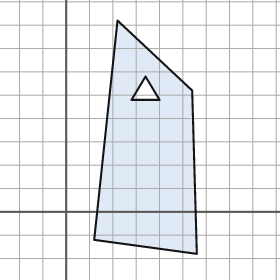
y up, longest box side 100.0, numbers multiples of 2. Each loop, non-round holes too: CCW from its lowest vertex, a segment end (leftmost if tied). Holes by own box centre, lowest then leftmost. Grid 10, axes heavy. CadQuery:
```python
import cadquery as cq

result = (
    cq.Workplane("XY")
    .moveTo(56.0, -18.0)
    .lineTo(54.0, 52.0)
    .lineTo(22.0, 82.0)
    .lineTo(12.0, -12.0)
    .close()
    .moveTo(28.0, 48.0)
    .lineTo(40.0, 48.0)
    .lineTo(34.0, 58.0)
    .close()
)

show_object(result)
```